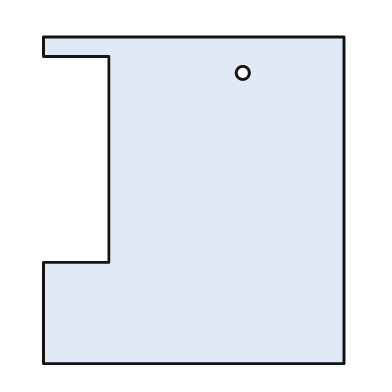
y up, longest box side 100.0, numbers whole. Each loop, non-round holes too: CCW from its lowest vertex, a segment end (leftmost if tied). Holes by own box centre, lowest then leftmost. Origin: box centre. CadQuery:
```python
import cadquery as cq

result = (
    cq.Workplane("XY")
    .moveTo(-46.0, -50.0)
    .lineTo(46.0, -50.0)
    .lineTo(46.0, 50.0)
    .lineTo(-46.0, 50.0)
    .lineTo(-46.0, 44.0)
    .lineTo(-26.0, 44.0)
    .lineTo(-26.0, -19.0)
    .lineTo(-46.0, -19.0)
    .close()
    .moveTo(15.0, 39.0)
    .circle(2.0)
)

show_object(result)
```